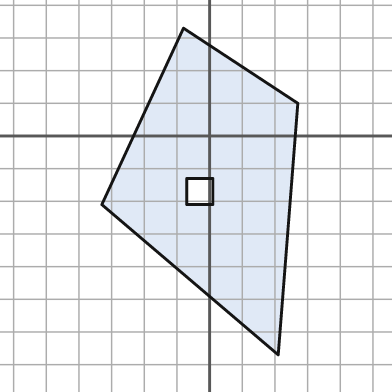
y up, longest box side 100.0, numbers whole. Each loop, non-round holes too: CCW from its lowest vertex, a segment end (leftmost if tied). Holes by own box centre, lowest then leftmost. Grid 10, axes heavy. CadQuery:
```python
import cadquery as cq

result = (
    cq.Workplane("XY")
    .moveTo(21.0, -67.0)
    .lineTo(27.0, 10.0)
    .lineTo(-8.0, 33.0)
    .lineTo(-33.0, -21.0)
    .close()
    .moveTo(-7.0, -21.0)
    .lineTo(1.0, -21.0)
    .lineTo(1.0, -13.0)
    .lineTo(-7.0, -13.0)
    .close()
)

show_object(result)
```